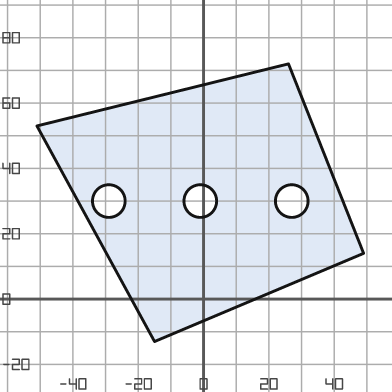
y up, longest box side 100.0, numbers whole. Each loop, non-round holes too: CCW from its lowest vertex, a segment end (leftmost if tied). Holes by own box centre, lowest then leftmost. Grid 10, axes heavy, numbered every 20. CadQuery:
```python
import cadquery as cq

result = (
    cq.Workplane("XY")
    .moveTo(-15.0, -13.0)
    .lineTo(49.0, 14.0)
    .lineTo(26.0, 72.0)
    .lineTo(-51.0, 53.0)
    .close()
    .moveTo(-29.0, 30.0)
    .circle(5.0)
    .moveTo(-1.0, 30.0)
    .circle(5.0)
    .moveTo(27.0, 30.0)
    .circle(5.0)
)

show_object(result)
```